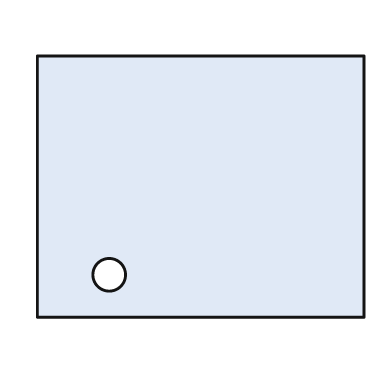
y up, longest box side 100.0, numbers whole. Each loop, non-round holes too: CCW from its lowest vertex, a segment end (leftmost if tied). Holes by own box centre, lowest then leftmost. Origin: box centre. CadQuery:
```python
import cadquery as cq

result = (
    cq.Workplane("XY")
    .moveTo(-50.0, -40.0)
    .lineTo(50.0, -40.0)
    .lineTo(50.0, 40.0)
    .lineTo(-50.0, 40.0)
    .close()
    .moveTo(-28.0, -27.0)
    .circle(5.0)
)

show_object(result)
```